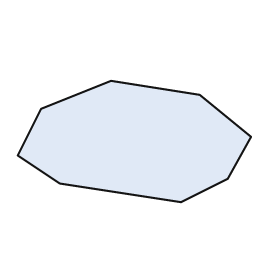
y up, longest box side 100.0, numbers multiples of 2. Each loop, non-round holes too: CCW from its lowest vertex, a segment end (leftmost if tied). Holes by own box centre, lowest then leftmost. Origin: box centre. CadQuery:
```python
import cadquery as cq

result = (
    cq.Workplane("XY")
    .moveTo(20.0, -26.0)
    .lineTo(40.0, -16.0)
    .lineTo(50.0, 2.0)
    .lineTo(28.0, 20.0)
    .lineTo(-10.0, 26.0)
    .lineTo(-40.0, 14.0)
    .lineTo(-50.0, -6.0)
    .lineTo(-32.0, -18.0)
    .close()
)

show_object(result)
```